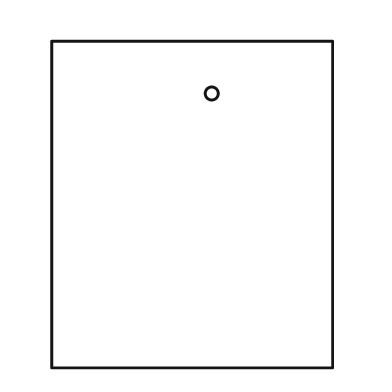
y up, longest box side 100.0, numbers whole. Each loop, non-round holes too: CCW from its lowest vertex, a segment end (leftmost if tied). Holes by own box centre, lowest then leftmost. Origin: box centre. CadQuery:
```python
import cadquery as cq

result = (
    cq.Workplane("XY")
    .moveTo(-43.0, -50.0)
    .lineTo(43.0, -50.0)
    .lineTo(43.0, 50.0)
    .lineTo(-43.0, 50.0)
    .close()
    .moveTo(6.0, 34.0)
    .circle(2.0)
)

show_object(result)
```